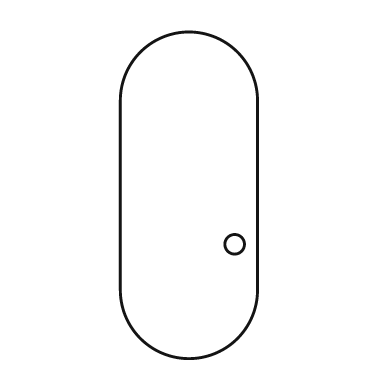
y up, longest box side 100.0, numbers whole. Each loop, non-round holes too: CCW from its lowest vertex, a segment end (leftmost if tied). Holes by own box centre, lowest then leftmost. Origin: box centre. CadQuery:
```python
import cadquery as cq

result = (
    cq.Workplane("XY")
    .moveTo(-21.0, -29.0)
    .threePointArc((0.0, -50.0), (21.0, -29.0))
    .lineTo(21.0, 29.0)
    .threePointArc((0.0, 50.0), (-21.0, 29.0))
    .close()
    .moveTo(14.0, -15.0)
    .circle(3.0)
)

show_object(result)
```